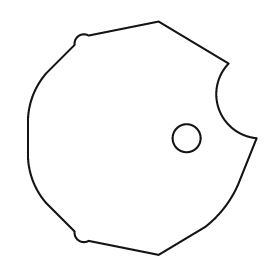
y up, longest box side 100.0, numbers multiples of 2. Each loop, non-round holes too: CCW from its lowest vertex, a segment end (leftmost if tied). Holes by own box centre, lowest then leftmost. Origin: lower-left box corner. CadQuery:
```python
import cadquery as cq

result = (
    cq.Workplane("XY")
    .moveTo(56.0, 0.0)
    .lineTo(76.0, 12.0)
    .threePointArc((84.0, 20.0), (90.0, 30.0))
    .lineTo(98.0, 50.0)
    .threePointArc((82.0, 62.0), (86.0, 82.0))
    .lineTo(56.0, 100.0)
    .lineTo(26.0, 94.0)
    .threePointArc((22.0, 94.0), (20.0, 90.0))
    .lineTo(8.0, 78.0)
    .threePointArc((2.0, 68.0), (0.0, 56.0))
    .lineTo(0.0, 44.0)
    .threePointArc((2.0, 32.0), (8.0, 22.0))
    .lineTo(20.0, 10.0)
    .threePointArc((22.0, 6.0), (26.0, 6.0))
    .close()
    .moveTo(68.0, 50.0)
    .circle(6.0)
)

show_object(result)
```